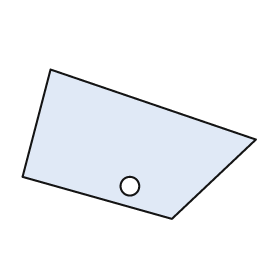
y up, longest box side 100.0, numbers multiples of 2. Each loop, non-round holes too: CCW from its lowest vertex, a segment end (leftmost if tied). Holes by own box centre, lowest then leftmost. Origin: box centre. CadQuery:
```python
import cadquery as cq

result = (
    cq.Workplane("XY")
    .moveTo(14.0, -32.0)
    .lineTo(50.0, 2.0)
    .lineTo(-38.0, 32.0)
    .lineTo(-50.0, -14.0)
    .close()
    .moveTo(-4.0, -18.0)
    .circle(4.0)
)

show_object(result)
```